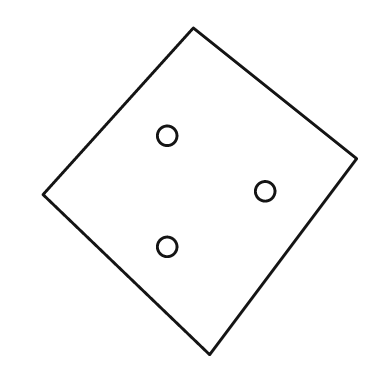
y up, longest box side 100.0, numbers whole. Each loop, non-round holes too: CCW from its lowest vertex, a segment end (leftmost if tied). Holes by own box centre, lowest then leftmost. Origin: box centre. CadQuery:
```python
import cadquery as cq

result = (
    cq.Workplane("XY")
    .moveTo(3.0, -50.0)
    .lineTo(48.0, 10.0)
    .lineTo(-2.0, 50.0)
    .lineTo(-48.0, -1.0)
    .close()
    .moveTo(-10.0, -17.0)
    .circle(3.0)
    .moveTo(20.0, 0.0)
    .circle(3.0)
    .moveTo(-10.0, 17.0)
    .circle(3.0)
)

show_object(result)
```